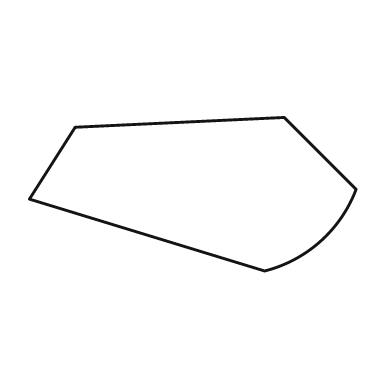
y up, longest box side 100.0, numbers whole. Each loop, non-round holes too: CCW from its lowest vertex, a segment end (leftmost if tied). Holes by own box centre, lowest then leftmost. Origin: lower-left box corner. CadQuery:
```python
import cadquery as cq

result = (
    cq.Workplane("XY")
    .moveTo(72.0, 0.0)
    .threePointArc((89.0, 9.0), (100.0, 25.0))
    .lineTo(78.0, 47.0)
    .lineTo(14.0, 44.0)
    .lineTo(0.0, 22.0)
    .close()
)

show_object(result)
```